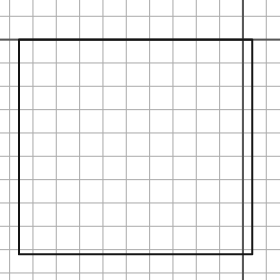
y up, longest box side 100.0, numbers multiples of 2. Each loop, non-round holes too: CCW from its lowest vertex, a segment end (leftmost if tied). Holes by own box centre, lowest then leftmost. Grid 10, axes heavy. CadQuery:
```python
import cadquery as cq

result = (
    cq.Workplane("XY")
    .moveTo(-96.0, -92.0)
    .lineTo(4.0, -92.0)
    .lineTo(4.0, 0.0)
    .lineTo(-96.0, 0.0)
    .close()
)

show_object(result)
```